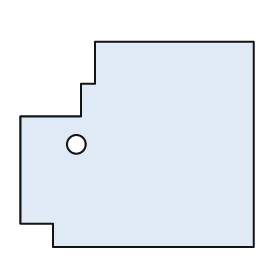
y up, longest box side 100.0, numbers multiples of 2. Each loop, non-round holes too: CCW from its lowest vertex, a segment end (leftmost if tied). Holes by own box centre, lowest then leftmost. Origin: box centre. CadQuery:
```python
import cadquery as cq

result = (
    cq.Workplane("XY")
    .moveTo(-36.0, -44.0)
    .lineTo(50.0, -44.0)
    .lineTo(50.0, 44.0)
    .lineTo(-18.0, 44.0)
    .lineTo(-18.0, 26.0)
    .lineTo(-24.0, 26.0)
    .lineTo(-24.0, 12.0)
    .lineTo(-50.0, 12.0)
    .lineTo(-50.0, -34.0)
    .lineTo(-36.0, -34.0)
    .close()
    .moveTo(-26.0, 0.0)
    .circle(4.0)
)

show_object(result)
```